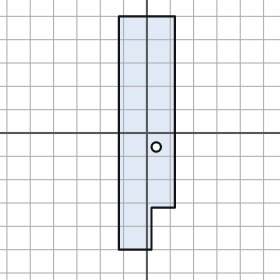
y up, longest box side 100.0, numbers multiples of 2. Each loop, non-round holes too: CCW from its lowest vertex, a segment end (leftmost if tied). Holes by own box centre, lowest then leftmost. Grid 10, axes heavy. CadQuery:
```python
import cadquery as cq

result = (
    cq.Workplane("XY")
    .moveTo(-12.0, -50.0)
    .lineTo(2.0, -50.0)
    .lineTo(2.0, -32.0)
    .lineTo(12.0, -32.0)
    .lineTo(12.0, 50.0)
    .lineTo(-12.0, 50.0)
    .close()
    .moveTo(4.0, -6.0)
    .circle(2.0)
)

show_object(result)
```